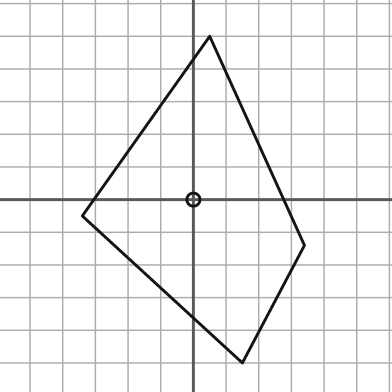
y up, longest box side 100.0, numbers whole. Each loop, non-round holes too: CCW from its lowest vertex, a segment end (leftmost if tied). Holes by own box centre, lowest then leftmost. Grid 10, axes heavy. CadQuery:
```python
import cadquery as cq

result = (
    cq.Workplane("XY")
    .moveTo(15.0, -50.0)
    .lineTo(34.0, -14.0)
    .lineTo(5.0, 50.0)
    .lineTo(-34.0, -5.0)
    .close()
    .moveTo(0.0, 0.0)
    .circle(2.0)
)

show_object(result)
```